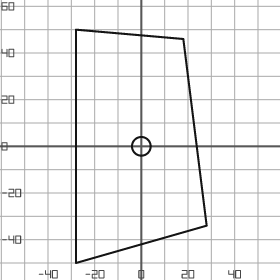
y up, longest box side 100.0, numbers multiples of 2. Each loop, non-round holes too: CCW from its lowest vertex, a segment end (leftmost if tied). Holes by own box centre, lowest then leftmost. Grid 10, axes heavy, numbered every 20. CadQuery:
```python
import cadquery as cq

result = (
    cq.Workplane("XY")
    .moveTo(-28.0, -50.0)
    .lineTo(28.0, -34.0)
    .lineTo(18.0, 46.0)
    .lineTo(-28.0, 50.0)
    .close()
    .moveTo(0.0, 0.0)
    .circle(4.0)
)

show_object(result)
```